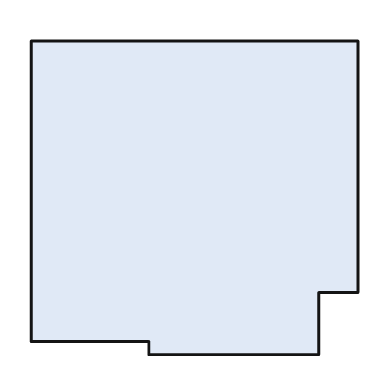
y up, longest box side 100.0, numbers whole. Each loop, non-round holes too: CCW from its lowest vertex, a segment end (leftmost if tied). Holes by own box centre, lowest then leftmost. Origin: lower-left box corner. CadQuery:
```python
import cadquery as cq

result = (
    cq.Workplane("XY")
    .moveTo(36.0, 0.0)
    .lineTo(88.0, 0.0)
    .lineTo(88.0, 19.0)
    .lineTo(100.0, 19.0)
    .lineTo(100.0, 96.0)
    .lineTo(0.0, 96.0)
    .lineTo(0.0, 4.0)
    .lineTo(36.0, 4.0)
    .close()
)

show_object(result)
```